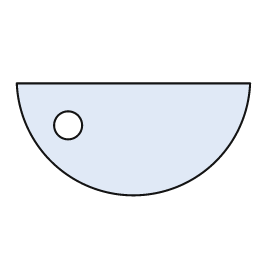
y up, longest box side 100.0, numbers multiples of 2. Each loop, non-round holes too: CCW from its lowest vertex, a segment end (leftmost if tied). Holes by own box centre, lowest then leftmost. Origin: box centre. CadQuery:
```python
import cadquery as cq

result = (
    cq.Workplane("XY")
    .moveTo(-50.0, 24.0)
    .threePointArc((0.0, -24.0), (50.0, 24.0))
    .close()
    .moveTo(-28.0, 6.0)
    .circle(6.0)
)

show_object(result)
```